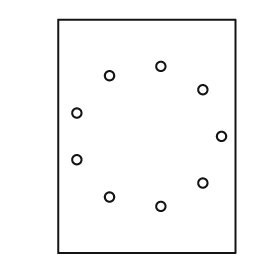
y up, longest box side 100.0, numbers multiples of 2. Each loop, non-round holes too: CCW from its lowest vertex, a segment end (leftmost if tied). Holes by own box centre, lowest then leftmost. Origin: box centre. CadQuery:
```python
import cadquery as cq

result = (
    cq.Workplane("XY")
    .moveTo(-38.0, -50.0)
    .lineTo(38.0, -50.0)
    .lineTo(38.0, 50.0)
    .lineTo(-38.0, 50.0)
    .close()
    .moveTo(6.0, -30.0)
    .circle(2.0)
    .moveTo(-16.0, -26.0)
    .circle(2.0)
    .moveTo(24.0, -20.0)
    .circle(2.0)
    .moveTo(-30.0, -10.0)
    .circle(2.0)
    .moveTo(32.0, 0.0)
    .circle(2.0)
    .moveTo(-30.0, 10.0)
    .circle(2.0)
    .moveTo(24.0, 20.0)
    .circle(2.0)
    .moveTo(-16.0, 26.0)
    .circle(2.0)
    .moveTo(6.0, 30.0)
    .circle(2.0)
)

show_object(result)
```